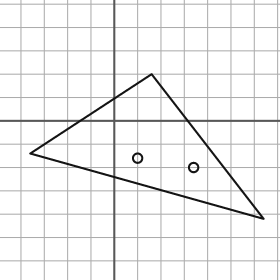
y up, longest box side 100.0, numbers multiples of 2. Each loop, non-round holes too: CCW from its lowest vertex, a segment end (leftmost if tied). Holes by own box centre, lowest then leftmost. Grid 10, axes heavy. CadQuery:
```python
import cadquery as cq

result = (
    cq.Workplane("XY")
    .moveTo(64.0, -42.0)
    .lineTo(16.0, 20.0)
    .lineTo(-36.0, -14.0)
    .close()
    .moveTo(34.0, -20.0)
    .circle(2.0)
    .moveTo(10.0, -16.0)
    .circle(2.0)
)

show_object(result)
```